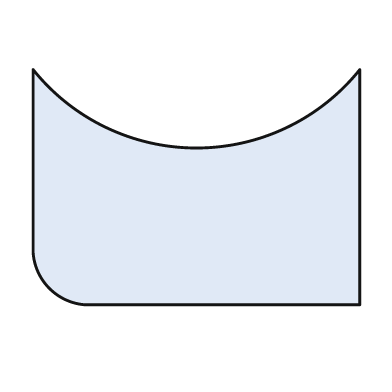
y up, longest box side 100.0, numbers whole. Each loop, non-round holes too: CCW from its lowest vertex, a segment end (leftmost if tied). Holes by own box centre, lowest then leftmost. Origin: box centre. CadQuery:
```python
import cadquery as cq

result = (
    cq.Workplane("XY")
    .moveTo(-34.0, -36.0)
    .lineTo(50.0, -36.0)
    .lineTo(50.0, 36.0)
    .threePointArc((0.0, 12.0), (-50.0, 36.0))
    .lineTo(-50.0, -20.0)
    .threePointArc((-45.0, -31.0), (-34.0, -36.0))
    .close()
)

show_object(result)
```